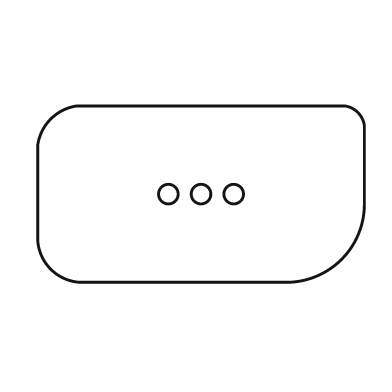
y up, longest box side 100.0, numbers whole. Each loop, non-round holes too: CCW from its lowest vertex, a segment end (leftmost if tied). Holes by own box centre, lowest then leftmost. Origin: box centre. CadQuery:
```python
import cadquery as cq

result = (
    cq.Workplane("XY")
    .moveTo(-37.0, -27.0)
    .lineTo(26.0, -27.0)
    .threePointArc((43.0, -20.0), (50.0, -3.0))
    .lineTo(50.0, 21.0)
    .threePointArc((48.0, 25.0), (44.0, 27.0))
    .lineTo(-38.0, 27.0)
    .threePointArc((-46.0, 23.0), (-50.0, 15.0))
    .lineTo(-50.0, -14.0)
    .threePointArc((-46.0, -23.0), (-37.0, -27.0))
    .close()
    .moveTo(-10.0, 0.0)
    .circle(3.0)
    .moveTo(0.0, 0.0)
    .circle(3.0)
    .moveTo(10.0, 0.0)
    .circle(3.0)
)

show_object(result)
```